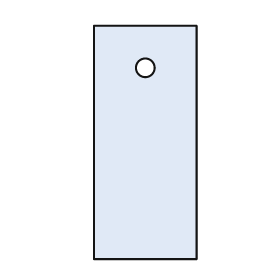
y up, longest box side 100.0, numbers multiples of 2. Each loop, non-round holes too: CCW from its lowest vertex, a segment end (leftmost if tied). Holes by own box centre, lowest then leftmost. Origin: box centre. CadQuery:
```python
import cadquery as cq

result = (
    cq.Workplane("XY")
    .moveTo(-22.0, -50.0)
    .lineTo(22.0, -50.0)
    .lineTo(22.0, 50.0)
    .lineTo(-22.0, 50.0)
    .close()
    .moveTo(0.0, 32.0)
    .circle(4.0)
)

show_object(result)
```